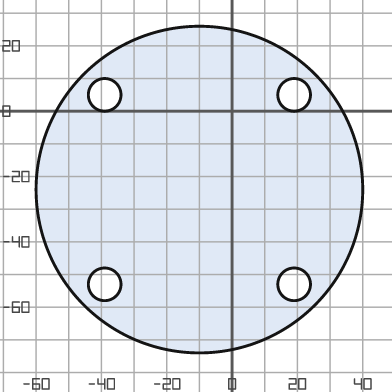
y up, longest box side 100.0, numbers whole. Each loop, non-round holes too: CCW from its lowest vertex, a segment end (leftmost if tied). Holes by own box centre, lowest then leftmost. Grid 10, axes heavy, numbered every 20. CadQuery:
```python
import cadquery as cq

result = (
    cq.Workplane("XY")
    .moveTo(-10.0, -24.0)
    .circle(50.0)
    .moveTo(-39.0, -53.0)
    .circle(5.0)
    .moveTo(19.0, -53.0)
    .circle(5.0)
    .moveTo(-39.0, 5.0)
    .circle(5.0)
    .moveTo(19.0, 5.0)
    .circle(5.0)
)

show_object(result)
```